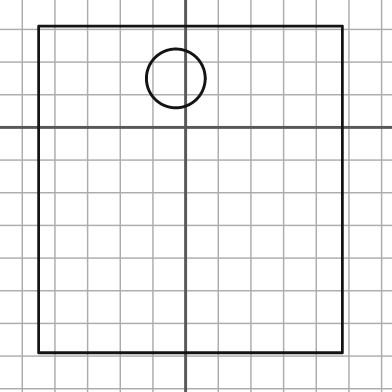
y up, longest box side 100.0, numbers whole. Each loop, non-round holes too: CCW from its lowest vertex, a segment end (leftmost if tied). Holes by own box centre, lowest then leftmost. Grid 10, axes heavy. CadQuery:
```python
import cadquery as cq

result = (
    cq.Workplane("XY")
    .moveTo(-45.0, -69.0)
    .lineTo(48.0, -69.0)
    .lineTo(48.0, 31.0)
    .lineTo(-45.0, 31.0)
    .close()
    .moveTo(-3.0, 15.0)
    .circle(9.0)
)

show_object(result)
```